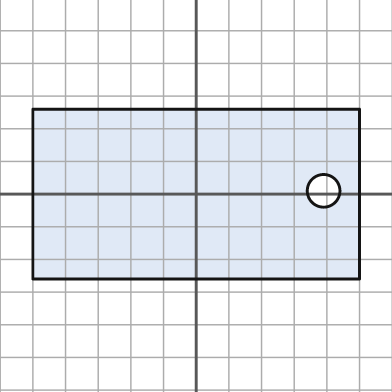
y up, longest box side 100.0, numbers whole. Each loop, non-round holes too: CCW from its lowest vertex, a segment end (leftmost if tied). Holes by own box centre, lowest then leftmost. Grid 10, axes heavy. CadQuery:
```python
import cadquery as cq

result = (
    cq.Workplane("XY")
    .moveTo(-50.0, -26.0)
    .lineTo(50.0, -26.0)
    .lineTo(50.0, 26.0)
    .lineTo(-50.0, 26.0)
    .close()
    .moveTo(39.0, 1.0)
    .circle(5.0)
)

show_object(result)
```